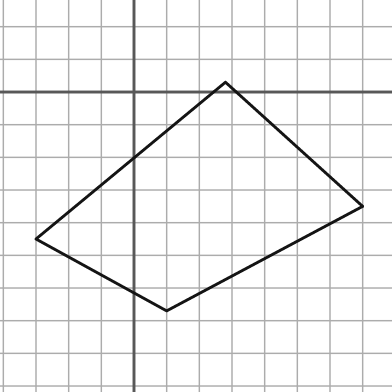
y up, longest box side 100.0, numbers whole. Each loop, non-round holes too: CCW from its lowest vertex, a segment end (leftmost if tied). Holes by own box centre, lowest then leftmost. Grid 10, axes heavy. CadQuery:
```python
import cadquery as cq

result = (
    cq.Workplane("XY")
    .moveTo(10.0, -67.0)
    .lineTo(70.0, -35.0)
    .lineTo(28.0, 3.0)
    .lineTo(-30.0, -45.0)
    .close()
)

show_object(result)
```